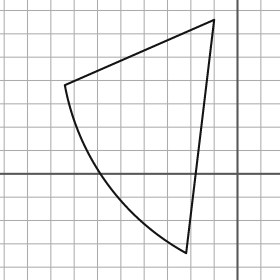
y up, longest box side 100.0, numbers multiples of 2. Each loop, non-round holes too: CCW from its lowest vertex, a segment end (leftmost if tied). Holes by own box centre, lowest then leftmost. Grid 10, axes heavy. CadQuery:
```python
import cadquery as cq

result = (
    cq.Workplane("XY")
    .moveTo(-22.0, -34.0)
    .lineTo(-10.0, 66.0)
    .lineTo(-74.0, 38.0)
    .threePointArc((-56.0, -4.0), (-22.0, -34.0))
    .close()
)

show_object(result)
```